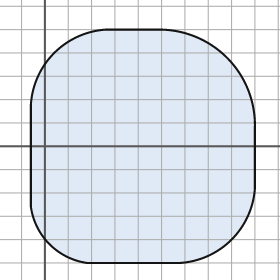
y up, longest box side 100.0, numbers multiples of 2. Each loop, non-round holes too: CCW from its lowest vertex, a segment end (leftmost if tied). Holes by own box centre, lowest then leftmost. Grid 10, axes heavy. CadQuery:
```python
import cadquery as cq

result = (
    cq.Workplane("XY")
    .moveTo(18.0, -50.0)
    .lineTo(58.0, -50.0)
    .threePointArc((80.0, -40.0), (90.0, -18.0))
    .lineTo(90.0, 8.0)
    .threePointArc((78.0, 38.0), (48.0, 50.0))
    .lineTo(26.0, 50.0)
    .threePointArc((4.0, 40.0), (-6.0, 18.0))
    .lineTo(-6.0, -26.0)
    .threePointArc((2.0, -42.0), (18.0, -50.0))
    .close()
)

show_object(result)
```